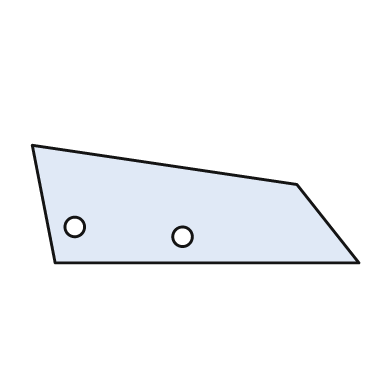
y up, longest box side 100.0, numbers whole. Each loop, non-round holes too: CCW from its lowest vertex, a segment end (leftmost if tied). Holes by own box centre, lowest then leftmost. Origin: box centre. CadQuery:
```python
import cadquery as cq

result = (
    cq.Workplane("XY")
    .moveTo(-43.0, -18.0)
    .lineTo(50.0, -18.0)
    .lineTo(31.0, 6.0)
    .lineTo(-50.0, 18.0)
    .close()
    .moveTo(-4.0, -10.0)
    .circle(3.0)
    .moveTo(-37.0, -7.0)
    .circle(3.0)
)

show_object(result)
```